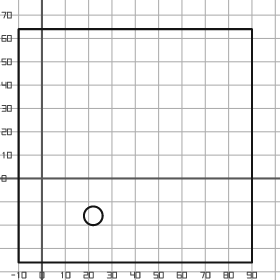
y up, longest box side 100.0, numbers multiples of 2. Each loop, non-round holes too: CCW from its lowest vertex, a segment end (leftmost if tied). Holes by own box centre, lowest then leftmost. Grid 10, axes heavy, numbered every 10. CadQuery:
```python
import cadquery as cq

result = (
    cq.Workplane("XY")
    .moveTo(-10.0, -36.0)
    .lineTo(90.0, -36.0)
    .lineTo(90.0, 64.0)
    .lineTo(-10.0, 64.0)
    .close()
    .moveTo(22.0, -16.0)
    .circle(4.0)
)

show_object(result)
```